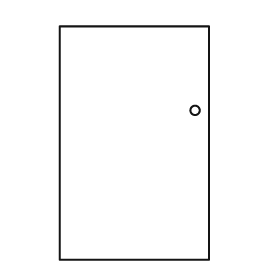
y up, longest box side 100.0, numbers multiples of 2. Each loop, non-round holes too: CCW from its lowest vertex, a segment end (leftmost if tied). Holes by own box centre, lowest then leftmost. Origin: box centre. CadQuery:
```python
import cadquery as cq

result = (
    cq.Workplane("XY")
    .moveTo(-32.0, -50.0)
    .lineTo(32.0, -50.0)
    .lineTo(32.0, 50.0)
    .lineTo(-32.0, 50.0)
    .close()
    .moveTo(26.0, 14.0)
    .circle(2.0)
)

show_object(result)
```